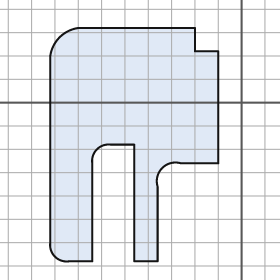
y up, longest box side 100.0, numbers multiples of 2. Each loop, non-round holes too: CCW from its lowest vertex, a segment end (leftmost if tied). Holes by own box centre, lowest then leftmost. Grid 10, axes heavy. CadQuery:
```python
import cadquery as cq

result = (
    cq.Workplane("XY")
    .moveTo(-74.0, -68.0)
    .lineTo(-64.0, -68.0)
    .lineTo(-64.0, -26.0)
    .threePointArc((-62.0, -20.0), (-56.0, -18.0))
    .lineTo(-46.0, -18.0)
    .lineTo(-46.0, -68.0)
    .lineTo(-36.0, -68.0)
    .lineTo(-36.0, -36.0)
    .threePointArc((-34.0, -28.0), (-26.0, -26.0))
    .lineTo(-10.0, -26.0)
    .lineTo(-10.0, 22.0)
    .lineTo(-20.0, 22.0)
    .lineTo(-20.0, 32.0)
    .lineTo(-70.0, 32.0)
    .threePointArc((-78.0, 28.0), (-82.0, 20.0))
    .lineTo(-82.0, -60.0)
    .threePointArc((-80.0, -66.0), (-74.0, -68.0))
    .close()
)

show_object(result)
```